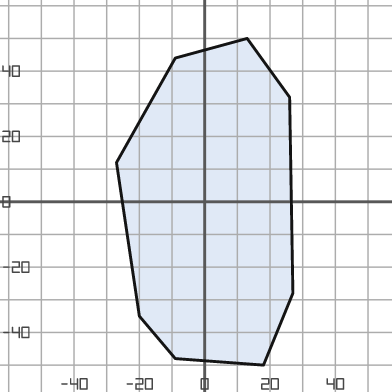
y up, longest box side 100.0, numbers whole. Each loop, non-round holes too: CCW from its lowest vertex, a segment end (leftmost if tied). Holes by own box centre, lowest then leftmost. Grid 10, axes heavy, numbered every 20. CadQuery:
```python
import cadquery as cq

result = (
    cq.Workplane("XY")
    .moveTo(18.0, -50.0)
    .lineTo(27.0, -28.0)
    .lineTo(26.0, 32.0)
    .lineTo(13.0, 50.0)
    .lineTo(-9.0, 44.0)
    .lineTo(-27.0, 12.0)
    .lineTo(-20.0, -35.0)
    .lineTo(-9.0, -48.0)
    .close()
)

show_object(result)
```